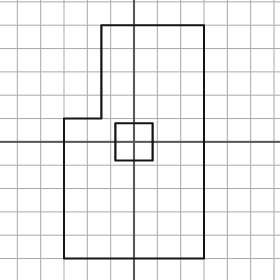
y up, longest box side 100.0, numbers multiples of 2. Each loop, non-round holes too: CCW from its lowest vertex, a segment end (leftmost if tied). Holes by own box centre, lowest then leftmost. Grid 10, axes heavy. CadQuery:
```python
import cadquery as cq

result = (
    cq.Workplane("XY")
    .moveTo(-30.0, -50.0)
    .lineTo(30.0, -50.0)
    .lineTo(30.0, 50.0)
    .lineTo(-14.0, 50.0)
    .lineTo(-14.0, 10.0)
    .lineTo(-30.0, 10.0)
    .close()
    .moveTo(-8.0, -8.0)
    .lineTo(8.0, -8.0)
    .lineTo(8.0, 8.0)
    .lineTo(-8.0, 8.0)
    .close()
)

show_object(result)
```